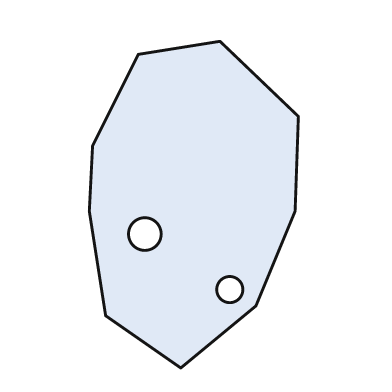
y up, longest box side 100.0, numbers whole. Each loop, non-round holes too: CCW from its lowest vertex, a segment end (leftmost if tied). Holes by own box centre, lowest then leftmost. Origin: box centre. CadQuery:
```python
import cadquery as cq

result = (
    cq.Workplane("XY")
    .moveTo(-4.0, -50.0)
    .lineTo(19.0, -31.0)
    .lineTo(31.0, -2.0)
    .lineTo(32.0, 27.0)
    .lineTo(8.0, 50.0)
    .lineTo(-17.0, 46.0)
    .lineTo(-31.0, 18.0)
    .lineTo(-32.0, -2.0)
    .lineTo(-27.0, -34.0)
    .close()
    .moveTo(11.0, -26.0)
    .circle(4.0)
    .moveTo(-15.0, -9.0)
    .circle(5.0)
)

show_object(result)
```